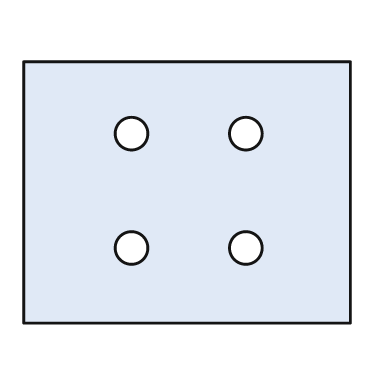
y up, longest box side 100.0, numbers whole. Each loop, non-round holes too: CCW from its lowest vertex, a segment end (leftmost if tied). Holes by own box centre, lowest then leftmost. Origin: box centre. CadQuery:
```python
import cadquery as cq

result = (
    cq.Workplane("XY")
    .moveTo(-50.0, -40.0)
    .lineTo(50.0, -40.0)
    .lineTo(50.0, 40.0)
    .lineTo(-50.0, 40.0)
    .close()
    .moveTo(-17.0, -17.0)
    .circle(5.0)
    .moveTo(18.0, -17.0)
    .circle(5.0)
    .moveTo(-17.0, 18.0)
    .circle(5.0)
    .moveTo(18.0, 18.0)
    .circle(5.0)
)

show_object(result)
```